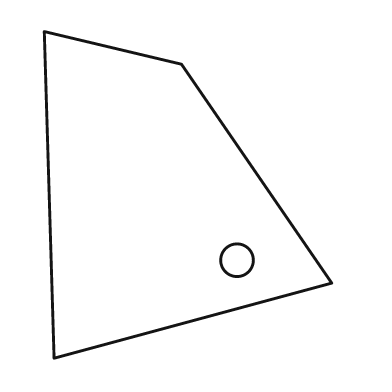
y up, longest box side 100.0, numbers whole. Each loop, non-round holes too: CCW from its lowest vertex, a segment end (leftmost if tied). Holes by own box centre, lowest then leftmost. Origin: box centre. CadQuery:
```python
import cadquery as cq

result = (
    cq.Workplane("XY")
    .moveTo(-41.0, -50.0)
    .lineTo(44.0, -27.0)
    .lineTo(-2.0, 40.0)
    .lineTo(-44.0, 50.0)
    .close()
    .moveTo(15.0, -20.0)
    .circle(5.0)
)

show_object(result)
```